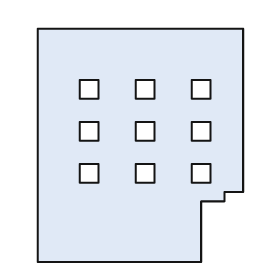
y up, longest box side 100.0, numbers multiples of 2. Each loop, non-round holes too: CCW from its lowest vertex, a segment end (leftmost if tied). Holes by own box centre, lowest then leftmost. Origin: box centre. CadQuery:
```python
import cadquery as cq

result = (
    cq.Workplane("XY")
    .moveTo(-44.0, -50.0)
    .lineTo(26.0, -50.0)
    .lineTo(26.0, -24.0)
    .lineTo(36.0, -24.0)
    .lineTo(36.0, -20.0)
    .lineTo(44.0, -20.0)
    .lineTo(44.0, 50.0)
    .lineTo(-44.0, 50.0)
    .close()
    .moveTo(-26.0, -16.0)
    .lineTo(-18.0, -16.0)
    .lineTo(-18.0, -8.0)
    .lineTo(-26.0, -8.0)
    .close()
    .moveTo(-2.0, -16.0)
    .lineTo(6.0, -16.0)
    .lineTo(6.0, -8.0)
    .lineTo(-2.0, -8.0)
    .close()
    .moveTo(22.0, -16.0)
    .lineTo(30.0, -16.0)
    .lineTo(30.0, -8.0)
    .lineTo(22.0, -8.0)
    .close()
    .moveTo(-26.0, 2.0)
    .lineTo(-18.0, 2.0)
    .lineTo(-18.0, 10.0)
    .lineTo(-26.0, 10.0)
    .close()
    .moveTo(-2.0, 2.0)
    .lineTo(6.0, 2.0)
    .lineTo(6.0, 10.0)
    .lineTo(-2.0, 10.0)
    .close()
    .moveTo(22.0, 2.0)
    .lineTo(30.0, 2.0)
    .lineTo(30.0, 10.0)
    .lineTo(22.0, 10.0)
    .close()
    .moveTo(-26.0, 20.0)
    .lineTo(-18.0, 20.0)
    .lineTo(-18.0, 28.0)
    .lineTo(-26.0, 28.0)
    .close()
    .moveTo(-2.0, 20.0)
    .lineTo(6.0, 20.0)
    .lineTo(6.0, 28.0)
    .lineTo(-2.0, 28.0)
    .close()
    .moveTo(22.0, 20.0)
    .lineTo(30.0, 20.0)
    .lineTo(30.0, 28.0)
    .lineTo(22.0, 28.0)
    .close()
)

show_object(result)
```